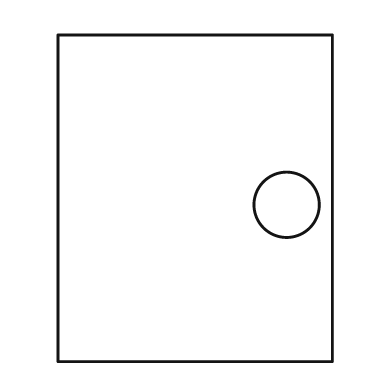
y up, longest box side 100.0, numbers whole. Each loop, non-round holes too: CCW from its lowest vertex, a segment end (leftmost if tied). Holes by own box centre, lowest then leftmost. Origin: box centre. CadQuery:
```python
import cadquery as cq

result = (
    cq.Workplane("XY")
    .moveTo(-42.0, -50.0)
    .lineTo(42.0, -50.0)
    .lineTo(42.0, 50.0)
    .lineTo(-42.0, 50.0)
    .close()
    .moveTo(28.0, -2.0)
    .circle(10.0)
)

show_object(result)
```